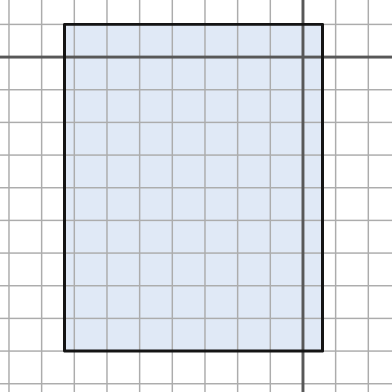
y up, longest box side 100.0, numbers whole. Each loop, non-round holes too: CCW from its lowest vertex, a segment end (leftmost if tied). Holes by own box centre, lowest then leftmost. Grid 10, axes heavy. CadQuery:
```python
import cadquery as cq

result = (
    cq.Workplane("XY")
    .moveTo(-73.0, -90.0)
    .lineTo(6.0, -90.0)
    .lineTo(6.0, 10.0)
    .lineTo(-73.0, 10.0)
    .close()
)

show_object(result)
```